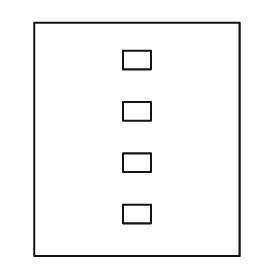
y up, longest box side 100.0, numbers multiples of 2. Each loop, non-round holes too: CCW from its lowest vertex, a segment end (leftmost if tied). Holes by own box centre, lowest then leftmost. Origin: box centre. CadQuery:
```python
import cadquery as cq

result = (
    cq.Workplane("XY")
    .moveTo(-44.0, -50.0)
    .lineTo(44.0, -50.0)
    .lineTo(44.0, 50.0)
    .lineTo(-44.0, 50.0)
    .close()
    .moveTo(-6.0, -36.0)
    .lineTo(6.0, -36.0)
    .lineTo(6.0, -28.0)
    .lineTo(-6.0, -28.0)
    .close()
    .moveTo(-6.0, -14.0)
    .lineTo(6.0, -14.0)
    .lineTo(6.0, -6.0)
    .lineTo(-6.0, -6.0)
    .close()
    .moveTo(-6.0, 8.0)
    .lineTo(6.0, 8.0)
    .lineTo(6.0, 16.0)
    .lineTo(-6.0, 16.0)
    .close()
    .moveTo(-6.0, 30.0)
    .lineTo(6.0, 30.0)
    .lineTo(6.0, 38.0)
    .lineTo(-6.0, 38.0)
    .close()
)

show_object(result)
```